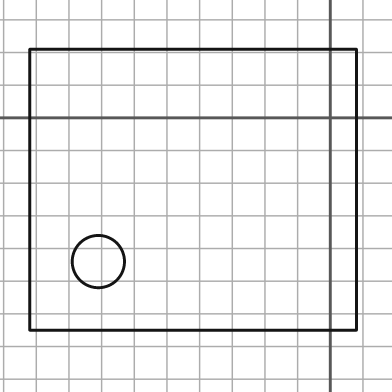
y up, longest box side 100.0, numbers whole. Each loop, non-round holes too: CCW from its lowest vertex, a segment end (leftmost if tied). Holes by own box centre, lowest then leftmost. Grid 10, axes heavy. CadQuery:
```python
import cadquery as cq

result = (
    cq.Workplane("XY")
    .moveTo(-92.0, -65.0)
    .lineTo(8.0, -65.0)
    .lineTo(8.0, 21.0)
    .lineTo(-92.0, 21.0)
    .close()
    .moveTo(-71.0, -44.0)
    .circle(8.0)
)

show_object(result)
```